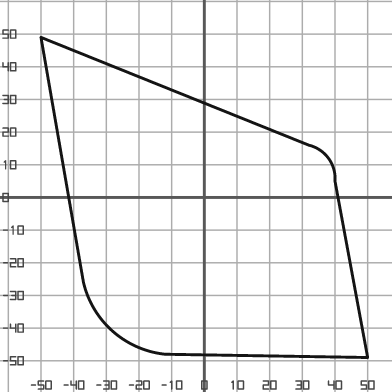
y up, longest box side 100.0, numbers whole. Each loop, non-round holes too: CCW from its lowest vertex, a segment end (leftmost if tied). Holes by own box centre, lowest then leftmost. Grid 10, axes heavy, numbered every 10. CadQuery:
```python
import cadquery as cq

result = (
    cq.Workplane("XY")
    .moveTo(50.0, -49.0)
    .lineTo(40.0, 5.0)
    .threePointArc((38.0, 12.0), (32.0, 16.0))
    .lineTo(-50.0, 49.0)
    .lineTo(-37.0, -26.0)
    .threePointArc((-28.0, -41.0), (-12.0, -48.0))
    .close()
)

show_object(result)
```